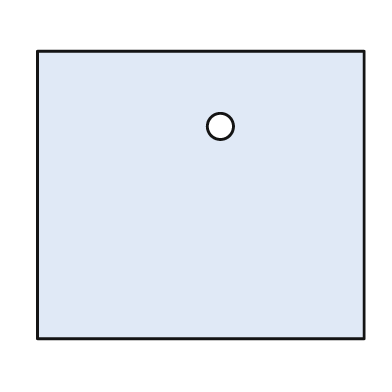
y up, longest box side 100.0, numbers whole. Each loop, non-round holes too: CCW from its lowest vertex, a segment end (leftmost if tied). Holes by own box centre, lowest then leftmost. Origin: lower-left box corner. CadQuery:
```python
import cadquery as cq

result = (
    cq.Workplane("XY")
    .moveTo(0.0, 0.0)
    .lineTo(100.0, 0.0)
    .lineTo(100.0, 88.0)
    .lineTo(0.0, 88.0)
    .close()
    .moveTo(56.0, 65.0)
    .circle(4.0)
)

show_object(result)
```